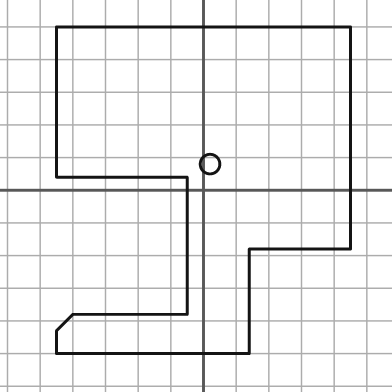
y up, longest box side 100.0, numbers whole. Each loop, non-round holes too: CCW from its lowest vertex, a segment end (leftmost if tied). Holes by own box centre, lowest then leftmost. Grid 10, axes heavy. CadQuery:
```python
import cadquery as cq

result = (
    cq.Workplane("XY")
    .moveTo(-45.0, -50.0)
    .lineTo(14.0, -50.0)
    .lineTo(14.0, -18.0)
    .lineTo(45.0, -18.0)
    .lineTo(45.0, 50.0)
    .lineTo(-45.0, 50.0)
    .lineTo(-45.0, 4.0)
    .lineTo(-5.0, 4.0)
    .lineTo(-5.0, -38.0)
    .lineTo(-40.0, -38.0)
    .lineTo(-45.0, -43.0)
    .close()
    .moveTo(2.0, 8.0)
    .circle(3.0)
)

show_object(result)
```